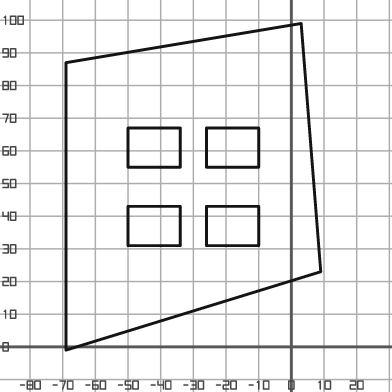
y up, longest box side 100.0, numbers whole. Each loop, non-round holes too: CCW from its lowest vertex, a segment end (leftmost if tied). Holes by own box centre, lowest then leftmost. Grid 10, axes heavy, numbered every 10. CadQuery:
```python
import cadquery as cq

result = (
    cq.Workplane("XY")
    .moveTo(-69.0, -1.0)
    .lineTo(9.0, 23.0)
    .lineTo(3.0, 99.0)
    .lineTo(-69.0, 87.0)
    .close()
    .moveTo(-50.0, 31.0)
    .lineTo(-34.0, 31.0)
    .lineTo(-34.0, 43.0)
    .lineTo(-50.0, 43.0)
    .close()
    .moveTo(-26.0, 31.0)
    .lineTo(-10.0, 31.0)
    .lineTo(-10.0, 43.0)
    .lineTo(-26.0, 43.0)
    .close()
    .moveTo(-50.0, 55.0)
    .lineTo(-34.0, 55.0)
    .lineTo(-34.0, 67.0)
    .lineTo(-50.0, 67.0)
    .close()
    .moveTo(-26.0, 55.0)
    .lineTo(-10.0, 55.0)
    .lineTo(-10.0, 67.0)
    .lineTo(-26.0, 67.0)
    .close()
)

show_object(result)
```